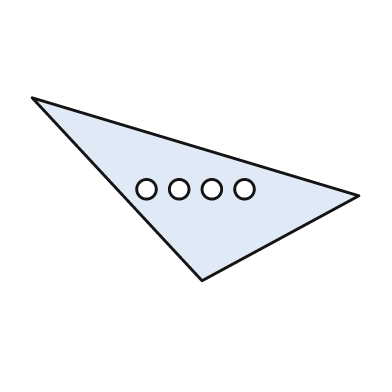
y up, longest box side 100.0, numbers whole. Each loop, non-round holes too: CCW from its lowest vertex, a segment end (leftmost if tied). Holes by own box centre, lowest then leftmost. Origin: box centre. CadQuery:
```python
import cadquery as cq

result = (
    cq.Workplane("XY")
    .moveTo(2.0, -28.0)
    .lineTo(50.0, -2.0)
    .lineTo(-50.0, 28.0)
    .close()
    .moveTo(-15.0, 0.0)
    .circle(3.0)
    .moveTo(-5.0, 0.0)
    .circle(3.0)
    .moveTo(5.0, 0.0)
    .circle(3.0)
    .moveTo(15.0, 0.0)
    .circle(3.0)
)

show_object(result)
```